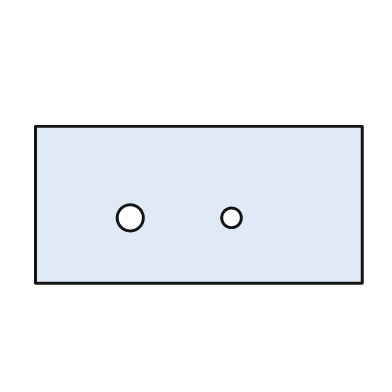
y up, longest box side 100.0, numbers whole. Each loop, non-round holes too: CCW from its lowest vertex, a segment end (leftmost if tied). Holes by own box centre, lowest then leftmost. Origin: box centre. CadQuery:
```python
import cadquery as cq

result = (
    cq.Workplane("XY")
    .moveTo(-50.0, -24.0)
    .lineTo(50.0, -24.0)
    .lineTo(50.0, 24.0)
    .lineTo(-50.0, 24.0)
    .close()
    .moveTo(-21.0, -4.0)
    .circle(4.0)
    .moveTo(10.0, -4.0)
    .circle(3.0)
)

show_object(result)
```